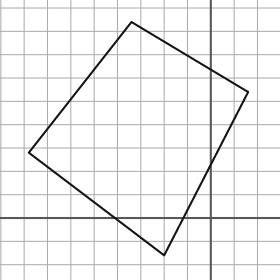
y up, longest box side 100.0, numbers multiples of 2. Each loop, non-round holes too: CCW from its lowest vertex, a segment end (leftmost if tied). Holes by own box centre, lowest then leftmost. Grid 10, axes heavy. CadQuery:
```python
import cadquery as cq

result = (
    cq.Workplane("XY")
    .moveTo(-20.0, -16.0)
    .lineTo(16.0, 54.0)
    .lineTo(-34.0, 84.0)
    .lineTo(-78.0, 28.0)
    .close()
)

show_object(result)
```